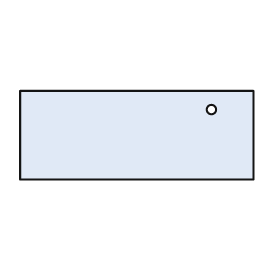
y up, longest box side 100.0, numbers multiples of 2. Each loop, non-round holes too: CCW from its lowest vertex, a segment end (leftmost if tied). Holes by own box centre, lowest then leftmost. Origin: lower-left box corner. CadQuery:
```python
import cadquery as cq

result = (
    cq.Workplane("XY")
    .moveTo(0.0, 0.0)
    .lineTo(100.0, 0.0)
    .lineTo(100.0, 38.0)
    .lineTo(0.0, 38.0)
    .close()
    .moveTo(82.0, 30.0)
    .circle(2.0)
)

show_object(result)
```